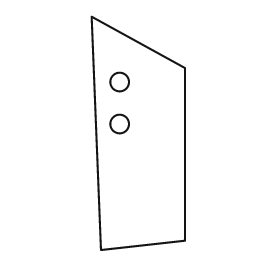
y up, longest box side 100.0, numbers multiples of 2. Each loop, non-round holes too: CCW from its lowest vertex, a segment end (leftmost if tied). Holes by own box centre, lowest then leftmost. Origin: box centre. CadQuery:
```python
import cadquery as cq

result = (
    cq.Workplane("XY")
    .moveTo(-16.0, -50.0)
    .lineTo(20.0, -46.0)
    .lineTo(20.0, 28.0)
    .lineTo(-20.0, 50.0)
    .close()
    .moveTo(-8.0, 4.0)
    .circle(4.0)
    .moveTo(-8.0, 22.0)
    .circle(4.0)
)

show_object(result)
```